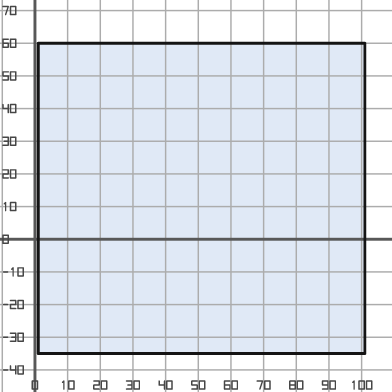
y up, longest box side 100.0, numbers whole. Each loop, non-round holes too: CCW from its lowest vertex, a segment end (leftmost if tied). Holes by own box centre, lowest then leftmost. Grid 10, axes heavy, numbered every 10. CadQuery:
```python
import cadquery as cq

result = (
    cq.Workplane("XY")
    .moveTo(1.0, -35.0)
    .lineTo(101.0, -35.0)
    .lineTo(101.0, 60.0)
    .lineTo(1.0, 60.0)
    .close()
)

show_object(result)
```